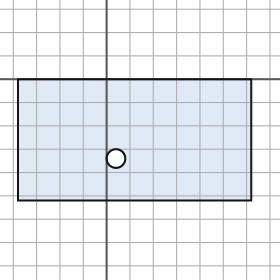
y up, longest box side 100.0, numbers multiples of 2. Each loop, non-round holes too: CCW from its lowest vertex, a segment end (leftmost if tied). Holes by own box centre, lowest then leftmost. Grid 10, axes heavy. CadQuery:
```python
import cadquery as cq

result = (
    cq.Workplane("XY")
    .moveTo(-38.0, -52.0)
    .lineTo(62.0, -52.0)
    .lineTo(62.0, 0.0)
    .lineTo(-38.0, 0.0)
    .close()
    .moveTo(4.0, -34.0)
    .circle(4.0)
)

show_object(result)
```